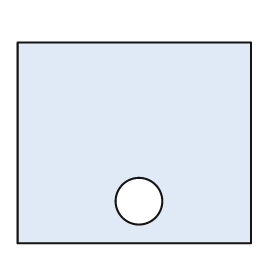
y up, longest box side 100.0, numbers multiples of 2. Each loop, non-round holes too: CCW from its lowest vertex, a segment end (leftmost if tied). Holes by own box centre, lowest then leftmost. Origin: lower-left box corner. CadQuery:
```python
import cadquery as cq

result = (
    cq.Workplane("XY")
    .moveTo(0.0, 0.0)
    .lineTo(100.0, 0.0)
    .lineTo(100.0, 86.0)
    .lineTo(0.0, 86.0)
    .close()
    .moveTo(52.0, 18.0)
    .circle(10.0)
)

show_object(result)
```